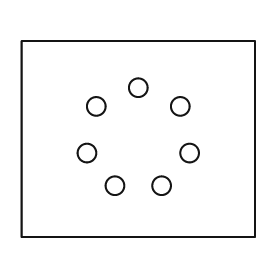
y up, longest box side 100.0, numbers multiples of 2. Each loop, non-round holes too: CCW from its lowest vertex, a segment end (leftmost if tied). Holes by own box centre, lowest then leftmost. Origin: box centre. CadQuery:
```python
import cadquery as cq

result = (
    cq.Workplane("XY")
    .moveTo(-50.0, -42.0)
    .lineTo(50.0, -42.0)
    .lineTo(50.0, 42.0)
    .lineTo(-50.0, 42.0)
    .close()
    .moveTo(-10.0, -20.0)
    .circle(4.0)
    .moveTo(10.0, -20.0)
    .circle(4.0)
    .moveTo(-22.0, -6.0)
    .circle(4.0)
    .moveTo(22.0, -6.0)
    .circle(4.0)
    .moveTo(-18.0, 14.0)
    .circle(4.0)
    .moveTo(18.0, 14.0)
    .circle(4.0)
    .moveTo(0.0, 22.0)
    .circle(4.0)
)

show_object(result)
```